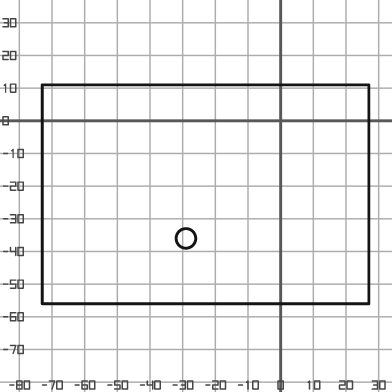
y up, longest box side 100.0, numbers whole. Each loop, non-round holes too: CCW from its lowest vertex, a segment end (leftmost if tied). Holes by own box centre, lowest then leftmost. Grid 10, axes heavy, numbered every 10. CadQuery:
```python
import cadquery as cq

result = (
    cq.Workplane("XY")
    .moveTo(-73.0, -56.0)
    .lineTo(27.0, -56.0)
    .lineTo(27.0, 11.0)
    .lineTo(-73.0, 11.0)
    .close()
    .moveTo(-29.0, -36.0)
    .circle(3.0)
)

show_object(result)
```